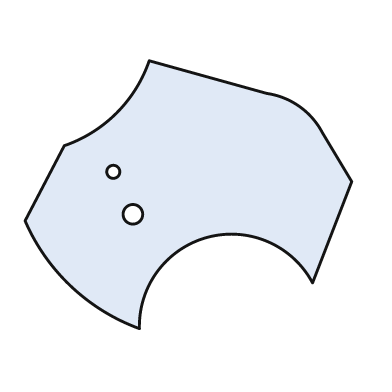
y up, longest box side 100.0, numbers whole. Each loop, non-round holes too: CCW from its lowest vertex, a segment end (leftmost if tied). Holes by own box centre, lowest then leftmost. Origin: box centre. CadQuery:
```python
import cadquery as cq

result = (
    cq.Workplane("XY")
    .moveTo(-15.0, -41.0)
    .threePointArc((6.0, -13.0), (38.0, -27.0))
    .lineTo(50.0, 4.0)
    .lineTo(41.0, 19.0)
    .threePointArc((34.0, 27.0), (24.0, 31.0))
    .lineTo(-12.0, 41.0)
    .threePointArc((-22.0, 25.0), (-38.0, 15.0))
    .lineTo(-50.0, -8.0)
    .threePointArc((-36.0, -28.0), (-15.0, -41.0))
    .close()
    .moveTo(-17.0, -6.0)
    .circle(3.0)
    .moveTo(-23.0, 7.0)
    .circle(2.0)
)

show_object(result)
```